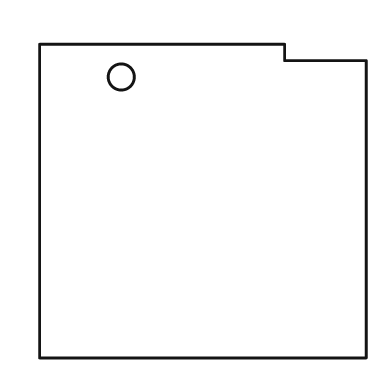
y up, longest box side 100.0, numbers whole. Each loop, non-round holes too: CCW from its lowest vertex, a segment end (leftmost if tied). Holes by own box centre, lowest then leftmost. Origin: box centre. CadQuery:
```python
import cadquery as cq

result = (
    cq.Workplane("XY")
    .moveTo(-50.0, -48.0)
    .lineTo(50.0, -48.0)
    .lineTo(50.0, 43.0)
    .lineTo(25.0, 43.0)
    .lineTo(25.0, 48.0)
    .lineTo(-50.0, 48.0)
    .close()
    .moveTo(-25.0, 38.0)
    .circle(4.0)
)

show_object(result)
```